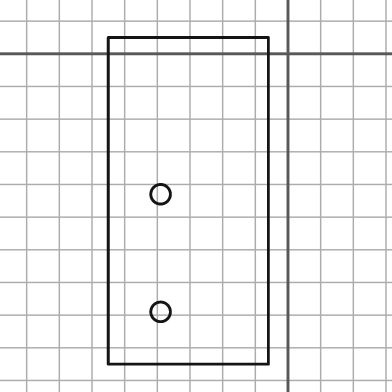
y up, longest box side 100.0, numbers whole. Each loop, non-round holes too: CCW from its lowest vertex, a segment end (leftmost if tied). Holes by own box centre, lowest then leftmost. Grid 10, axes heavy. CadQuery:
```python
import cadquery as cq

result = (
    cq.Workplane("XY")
    .moveTo(-55.0, -95.0)
    .lineTo(-6.0, -95.0)
    .lineTo(-6.0, 5.0)
    .lineTo(-55.0, 5.0)
    .close()
    .moveTo(-39.0, -79.0)
    .circle(3.0)
    .moveTo(-39.0, -43.0)
    .circle(3.0)
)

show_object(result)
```